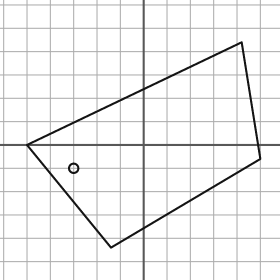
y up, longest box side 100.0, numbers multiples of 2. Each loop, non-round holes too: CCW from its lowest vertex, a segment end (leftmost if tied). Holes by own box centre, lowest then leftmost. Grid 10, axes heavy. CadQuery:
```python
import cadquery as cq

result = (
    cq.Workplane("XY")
    .moveTo(-14.0, -44.0)
    .lineTo(50.0, -6.0)
    .lineTo(42.0, 44.0)
    .lineTo(-50.0, 0.0)
    .close()
    .moveTo(-30.0, -10.0)
    .circle(2.0)
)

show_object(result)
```